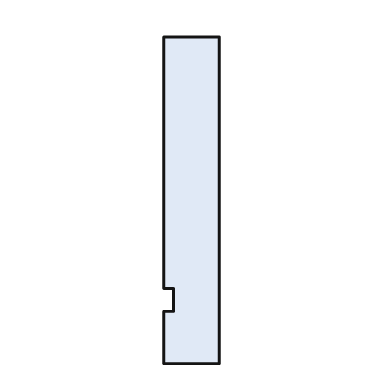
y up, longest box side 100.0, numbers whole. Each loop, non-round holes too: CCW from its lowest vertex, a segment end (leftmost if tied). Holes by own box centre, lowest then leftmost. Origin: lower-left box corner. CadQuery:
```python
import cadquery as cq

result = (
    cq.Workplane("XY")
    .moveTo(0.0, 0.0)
    .lineTo(17.0, 0.0)
    .lineTo(17.0, 100.0)
    .lineTo(0.0, 100.0)
    .lineTo(0.0, 23.0)
    .lineTo(3.0, 23.0)
    .lineTo(3.0, 16.0)
    .lineTo(0.0, 16.0)
    .close()
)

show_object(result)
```